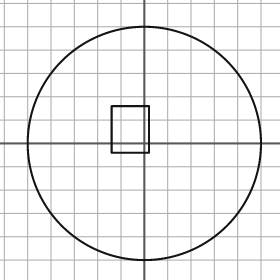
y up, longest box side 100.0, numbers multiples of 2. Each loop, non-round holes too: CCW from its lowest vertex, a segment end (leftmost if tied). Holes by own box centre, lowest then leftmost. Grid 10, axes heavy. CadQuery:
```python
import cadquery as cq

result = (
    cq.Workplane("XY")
    .moveTo(0.0, 0.0)
    .circle(50.0)
    .moveTo(-14.0, -4.0)
    .lineTo(2.0, -4.0)
    .lineTo(2.0, 16.0)
    .lineTo(-14.0, 16.0)
    .close()
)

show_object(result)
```